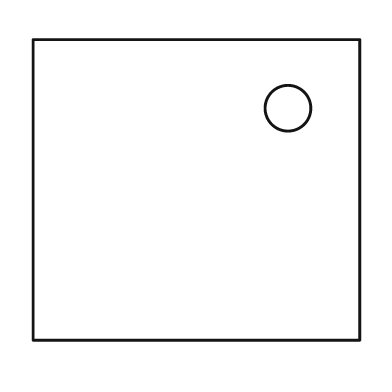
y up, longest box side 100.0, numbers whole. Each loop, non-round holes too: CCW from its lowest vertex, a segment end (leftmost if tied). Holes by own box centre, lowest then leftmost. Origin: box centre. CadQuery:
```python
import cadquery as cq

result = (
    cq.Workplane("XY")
    .moveTo(-50.0, -46.0)
    .lineTo(50.0, -46.0)
    .lineTo(50.0, 46.0)
    .lineTo(-50.0, 46.0)
    .close()
    .moveTo(28.0, 25.0)
    .circle(7.0)
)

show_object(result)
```